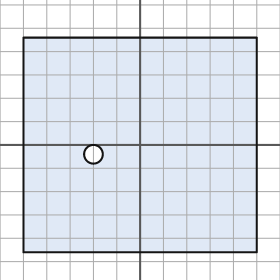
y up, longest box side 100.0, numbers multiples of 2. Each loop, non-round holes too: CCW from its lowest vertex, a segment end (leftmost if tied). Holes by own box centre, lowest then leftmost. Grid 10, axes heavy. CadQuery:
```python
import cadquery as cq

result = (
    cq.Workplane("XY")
    .moveTo(-50.0, -46.0)
    .lineTo(50.0, -46.0)
    .lineTo(50.0, 46.0)
    .lineTo(-50.0, 46.0)
    .close()
    .moveTo(-20.0, -4.0)
    .circle(4.0)
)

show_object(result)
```